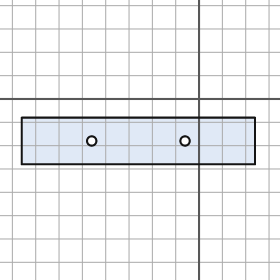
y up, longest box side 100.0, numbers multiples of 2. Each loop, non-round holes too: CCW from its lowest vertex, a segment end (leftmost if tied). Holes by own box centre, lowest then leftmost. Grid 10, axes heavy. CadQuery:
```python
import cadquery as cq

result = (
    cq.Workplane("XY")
    .moveTo(-76.0, -28.0)
    .lineTo(24.0, -28.0)
    .lineTo(24.0, -8.0)
    .lineTo(-76.0, -8.0)
    .close()
    .moveTo(-46.0, -18.0)
    .circle(2.0)
    .moveTo(-6.0, -18.0)
    .circle(2.0)
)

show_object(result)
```